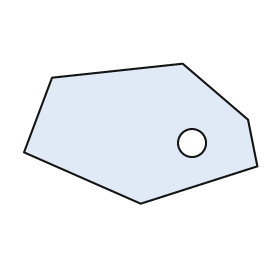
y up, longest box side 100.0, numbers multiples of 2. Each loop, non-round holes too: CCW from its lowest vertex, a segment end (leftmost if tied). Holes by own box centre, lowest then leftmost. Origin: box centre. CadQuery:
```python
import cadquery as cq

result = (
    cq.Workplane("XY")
    .moveTo(0.0, -30.0)
    .lineTo(50.0, -14.0)
    .lineTo(46.0, 6.0)
    .lineTo(18.0, 30.0)
    .lineTo(-38.0, 24.0)
    .lineTo(-50.0, -8.0)
    .close()
    .moveTo(22.0, -4.0)
    .circle(6.0)
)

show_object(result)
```